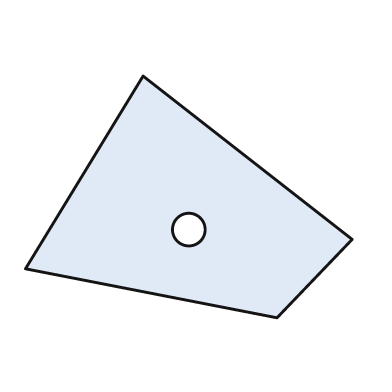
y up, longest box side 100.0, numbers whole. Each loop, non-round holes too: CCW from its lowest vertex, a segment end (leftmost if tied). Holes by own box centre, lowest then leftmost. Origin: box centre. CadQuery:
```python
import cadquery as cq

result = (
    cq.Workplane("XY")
    .moveTo(27.0, -37.0)
    .lineTo(50.0, -13.0)
    .lineTo(-14.0, 37.0)
    .lineTo(-50.0, -22.0)
    .close()
    .moveTo(0.0, -10.0)
    .circle(5.0)
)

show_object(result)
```